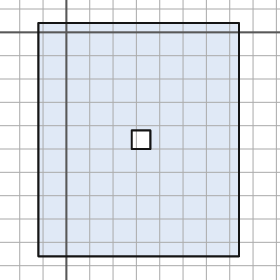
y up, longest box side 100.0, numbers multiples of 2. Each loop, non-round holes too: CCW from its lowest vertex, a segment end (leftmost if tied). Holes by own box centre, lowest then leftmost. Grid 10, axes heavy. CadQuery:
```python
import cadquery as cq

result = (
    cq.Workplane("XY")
    .moveTo(-12.0, -96.0)
    .lineTo(74.0, -96.0)
    .lineTo(74.0, 4.0)
    .lineTo(-12.0, 4.0)
    .close()
    .moveTo(28.0, -50.0)
    .lineTo(36.0, -50.0)
    .lineTo(36.0, -42.0)
    .lineTo(28.0, -42.0)
    .close()
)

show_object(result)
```